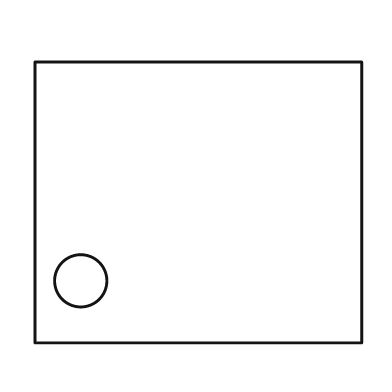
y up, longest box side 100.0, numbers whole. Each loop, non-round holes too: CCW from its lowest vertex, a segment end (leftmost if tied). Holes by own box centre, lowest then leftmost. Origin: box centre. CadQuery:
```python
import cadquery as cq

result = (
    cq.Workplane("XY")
    .moveTo(-50.0, -43.0)
    .lineTo(50.0, -43.0)
    .lineTo(50.0, 43.0)
    .lineTo(-50.0, 43.0)
    .close()
    .moveTo(-36.0, -24.0)
    .circle(8.0)
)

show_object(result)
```